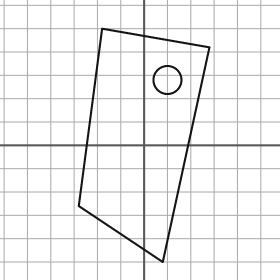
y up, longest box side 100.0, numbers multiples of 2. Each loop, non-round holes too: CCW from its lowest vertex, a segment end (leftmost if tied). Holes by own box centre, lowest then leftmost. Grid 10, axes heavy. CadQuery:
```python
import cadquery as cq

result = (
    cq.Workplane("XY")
    .moveTo(8.0, -50.0)
    .lineTo(28.0, 42.0)
    .lineTo(-18.0, 50.0)
    .lineTo(-28.0, -26.0)
    .close()
    .moveTo(10.0, 28.0)
    .circle(6.0)
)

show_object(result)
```